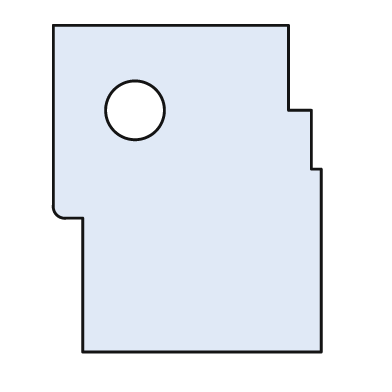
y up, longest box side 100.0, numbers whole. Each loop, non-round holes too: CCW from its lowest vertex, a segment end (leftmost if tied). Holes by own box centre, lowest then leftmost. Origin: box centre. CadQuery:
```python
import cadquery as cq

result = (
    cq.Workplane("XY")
    .moveTo(-32.0, -50.0)
    .lineTo(41.0, -50.0)
    .lineTo(41.0, 6.0)
    .lineTo(38.0, 6.0)
    .lineTo(38.0, 24.0)
    .lineTo(31.0, 24.0)
    .lineTo(31.0, 50.0)
    .lineTo(-41.0, 50.0)
    .lineTo(-41.0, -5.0)
    .threePointArc((-40.0, -8.0), (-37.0, -9.0))
    .lineTo(-32.0, -9.0)
    .close()
    .moveTo(-16.0, 24.0)
    .circle(9.0)
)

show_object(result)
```